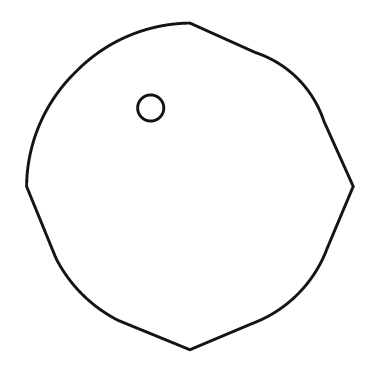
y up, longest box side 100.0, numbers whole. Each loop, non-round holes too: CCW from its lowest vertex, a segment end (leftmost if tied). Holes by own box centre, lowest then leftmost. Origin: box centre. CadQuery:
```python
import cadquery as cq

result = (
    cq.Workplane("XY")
    .moveTo(0.0, -50.0)
    .lineTo(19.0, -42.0)
    .threePointArc((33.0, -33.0), (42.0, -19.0))
    .lineTo(50.0, 0.0)
    .lineTo(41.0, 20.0)
    .threePointArc((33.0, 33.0), (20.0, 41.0))
    .lineTo(0.0, 50.0)
    .threePointArc((-19.0, 46.0), (-35.0, 35.0))
    .threePointArc((-46.0, 19.0), (-50.0, 0.0))
    .lineTo(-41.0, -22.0)
    .threePointArc((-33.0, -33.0), (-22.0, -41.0))
    .close()
    .moveTo(-12.0, 24.0)
    .circle(4.0)
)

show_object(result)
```